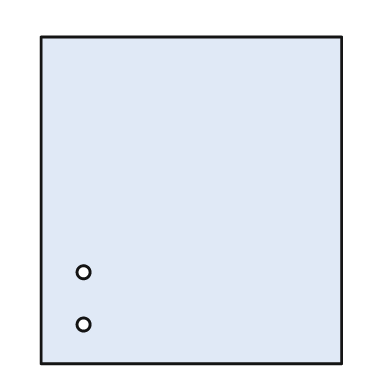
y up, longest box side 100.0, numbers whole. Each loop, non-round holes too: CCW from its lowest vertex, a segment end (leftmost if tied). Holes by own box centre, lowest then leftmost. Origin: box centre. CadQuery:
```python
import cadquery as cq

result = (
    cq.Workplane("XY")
    .moveTo(-46.0, -50.0)
    .lineTo(46.0, -50.0)
    .lineTo(46.0, 50.0)
    .lineTo(-46.0, 50.0)
    .close()
    .moveTo(-33.0, -38.0)
    .circle(2.0)
    .moveTo(-33.0, -22.0)
    .circle(2.0)
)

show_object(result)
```